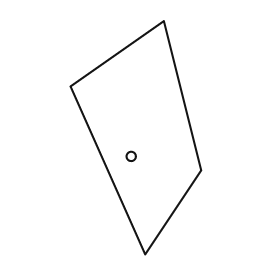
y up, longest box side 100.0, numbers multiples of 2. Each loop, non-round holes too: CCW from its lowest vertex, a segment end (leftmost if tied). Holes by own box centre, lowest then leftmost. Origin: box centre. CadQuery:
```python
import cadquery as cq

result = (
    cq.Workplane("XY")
    .moveTo(4.0, -50.0)
    .lineTo(28.0, -14.0)
    .lineTo(12.0, 50.0)
    .lineTo(-28.0, 22.0)
    .close()
    .moveTo(-2.0, -8.0)
    .circle(2.0)
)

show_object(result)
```